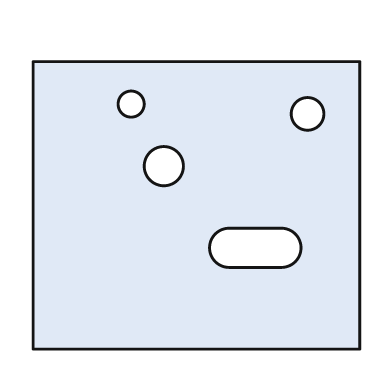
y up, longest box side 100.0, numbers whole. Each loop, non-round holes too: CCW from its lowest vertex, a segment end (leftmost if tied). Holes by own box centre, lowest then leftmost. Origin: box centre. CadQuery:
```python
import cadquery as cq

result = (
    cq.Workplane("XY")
    .moveTo(-50.0, -44.0)
    .lineTo(50.0, -44.0)
    .lineTo(50.0, 44.0)
    .lineTo(-50.0, 44.0)
    .close()
    .moveTo(10.0, -19.0)
    .lineTo(26.0, -19.0)
    .threePointArc((32.0, -13.0), (26.0, -7.0))
    .lineTo(10.0, -7.0)
    .threePointArc((4.0, -13.0), (10.0, -19.0))
    .close()
    .moveTo(-10.0, 12.0)
    .circle(6.0)
    .moveTo(34.0, 28.0)
    .circle(5.0)
    .moveTo(-20.0, 31.0)
    .circle(4.0)
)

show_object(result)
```